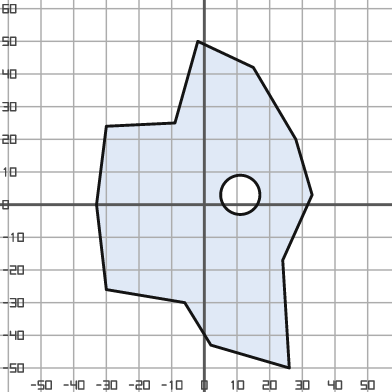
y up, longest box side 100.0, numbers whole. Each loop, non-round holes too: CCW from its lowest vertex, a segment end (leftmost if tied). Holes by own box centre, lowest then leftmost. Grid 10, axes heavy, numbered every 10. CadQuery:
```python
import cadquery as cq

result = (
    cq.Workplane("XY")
    .moveTo(26.0, -50.0)
    .lineTo(24.0, -17.0)
    .lineTo(33.0, 3.0)
    .lineTo(28.0, 20.0)
    .lineTo(15.0, 42.0)
    .lineTo(-2.0, 50.0)
    .lineTo(-9.0, 25.0)
    .lineTo(-30.0, 24.0)
    .lineTo(-33.0, 0.0)
    .lineTo(-30.0, -26.0)
    .lineTo(-6.0, -30.0)
    .lineTo(2.0, -43.0)
    .close()
    .moveTo(11.0, 3.0)
    .circle(6.0)
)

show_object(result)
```